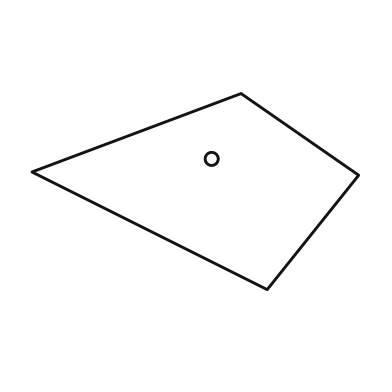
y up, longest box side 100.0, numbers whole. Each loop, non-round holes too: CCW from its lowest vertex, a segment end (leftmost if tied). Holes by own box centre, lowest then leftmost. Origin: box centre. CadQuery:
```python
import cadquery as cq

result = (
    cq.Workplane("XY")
    .moveTo(22.0, -30.0)
    .lineTo(50.0, 5.0)
    .lineTo(14.0, 30.0)
    .lineTo(-50.0, 6.0)
    .close()
    .moveTo(5.0, 10.0)
    .circle(2.0)
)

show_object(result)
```